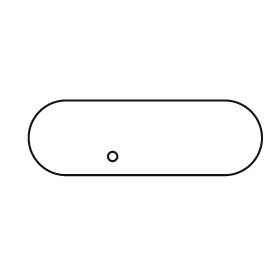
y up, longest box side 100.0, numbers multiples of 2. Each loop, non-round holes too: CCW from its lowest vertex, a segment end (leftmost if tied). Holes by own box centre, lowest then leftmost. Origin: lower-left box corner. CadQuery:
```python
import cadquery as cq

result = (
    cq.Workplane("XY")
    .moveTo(16.0, 0.0)
    .lineTo(84.0, 0.0)
    .threePointArc((100.0, 16.0), (84.0, 32.0))
    .lineTo(16.0, 32.0)
    .threePointArc((0.0, 16.0), (16.0, 0.0))
    .close()
    .moveTo(36.0, 8.0)
    .circle(2.0)
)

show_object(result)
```